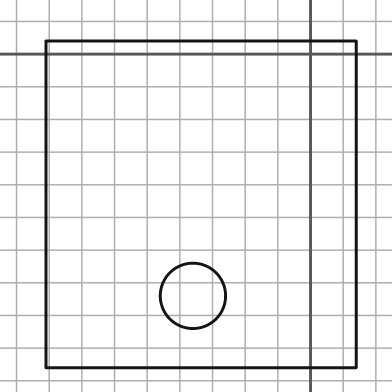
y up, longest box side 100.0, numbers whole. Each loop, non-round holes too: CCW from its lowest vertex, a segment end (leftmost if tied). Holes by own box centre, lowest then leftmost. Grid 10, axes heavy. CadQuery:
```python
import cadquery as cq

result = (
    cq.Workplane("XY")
    .moveTo(-81.0, -96.0)
    .lineTo(14.0, -96.0)
    .lineTo(14.0, 4.0)
    .lineTo(-81.0, 4.0)
    .close()
    .moveTo(-36.0, -74.0)
    .circle(10.0)
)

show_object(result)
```